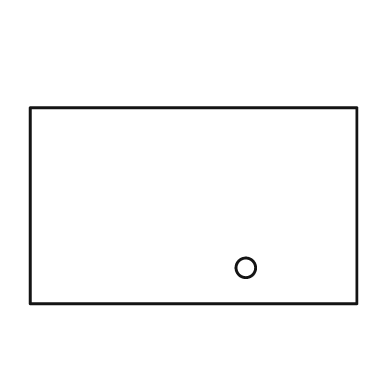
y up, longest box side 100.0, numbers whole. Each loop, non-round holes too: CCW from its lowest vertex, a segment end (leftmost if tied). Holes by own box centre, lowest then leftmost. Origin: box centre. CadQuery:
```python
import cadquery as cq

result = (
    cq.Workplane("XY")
    .moveTo(-50.0, -30.0)
    .lineTo(50.0, -30.0)
    .lineTo(50.0, 30.0)
    .lineTo(-50.0, 30.0)
    .close()
    .moveTo(16.0, -19.0)
    .circle(3.0)
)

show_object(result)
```